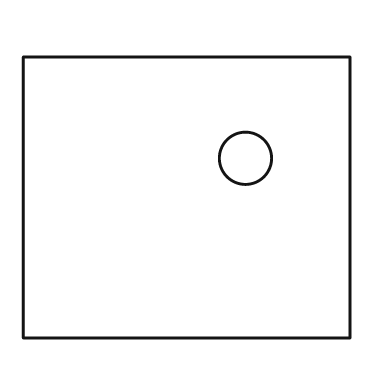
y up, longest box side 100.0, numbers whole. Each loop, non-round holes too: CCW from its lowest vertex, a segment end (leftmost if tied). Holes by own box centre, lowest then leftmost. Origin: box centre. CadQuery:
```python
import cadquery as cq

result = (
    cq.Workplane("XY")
    .moveTo(-50.0, -43.0)
    .lineTo(50.0, -43.0)
    .lineTo(50.0, 43.0)
    .lineTo(-50.0, 43.0)
    .close()
    .moveTo(18.0, 12.0)
    .circle(8.0)
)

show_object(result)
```